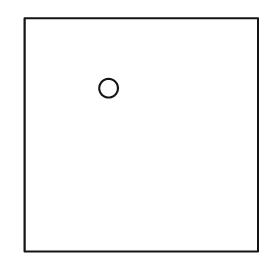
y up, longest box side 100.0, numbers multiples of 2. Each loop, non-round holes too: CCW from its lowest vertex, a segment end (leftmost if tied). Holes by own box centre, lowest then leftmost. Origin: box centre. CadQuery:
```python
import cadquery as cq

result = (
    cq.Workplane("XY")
    .moveTo(-50.0, -50.0)
    .lineTo(50.0, -50.0)
    .lineTo(50.0, 50.0)
    .lineTo(-50.0, 50.0)
    .close()
    .moveTo(-14.0, 20.0)
    .circle(4.0)
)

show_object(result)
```